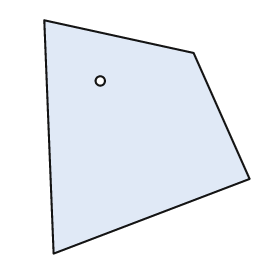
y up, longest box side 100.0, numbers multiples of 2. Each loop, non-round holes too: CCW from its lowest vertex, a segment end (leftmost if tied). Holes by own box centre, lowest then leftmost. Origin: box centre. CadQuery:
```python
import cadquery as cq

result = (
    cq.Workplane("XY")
    .moveTo(-40.0, -50.0)
    .lineTo(44.0, -18.0)
    .lineTo(20.0, 36.0)
    .lineTo(-44.0, 50.0)
    .close()
    .moveTo(-20.0, 24.0)
    .circle(2.0)
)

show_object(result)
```